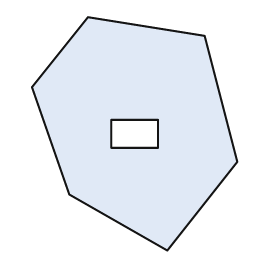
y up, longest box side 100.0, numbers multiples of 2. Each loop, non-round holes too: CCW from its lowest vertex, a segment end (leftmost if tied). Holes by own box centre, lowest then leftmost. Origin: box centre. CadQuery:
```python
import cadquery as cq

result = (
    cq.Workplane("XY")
    .moveTo(14.0, -50.0)
    .lineTo(44.0, -12.0)
    .lineTo(30.0, 42.0)
    .lineTo(-20.0, 50.0)
    .lineTo(-44.0, 20.0)
    .lineTo(-28.0, -26.0)
    .close()
    .moveTo(-10.0, -6.0)
    .lineTo(10.0, -6.0)
    .lineTo(10.0, 6.0)
    .lineTo(-10.0, 6.0)
    .close()
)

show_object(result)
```